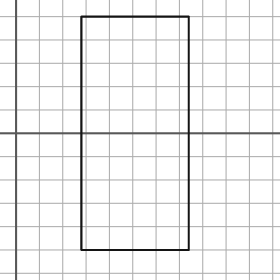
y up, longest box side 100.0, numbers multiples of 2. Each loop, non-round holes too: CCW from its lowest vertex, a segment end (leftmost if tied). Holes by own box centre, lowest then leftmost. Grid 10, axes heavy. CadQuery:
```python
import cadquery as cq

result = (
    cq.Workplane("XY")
    .moveTo(28.0, -50.0)
    .lineTo(74.0, -50.0)
    .lineTo(74.0, 50.0)
    .lineTo(28.0, 50.0)
    .close()
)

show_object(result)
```